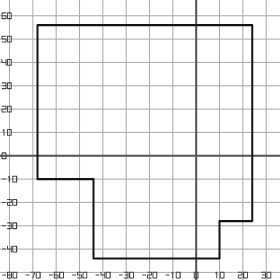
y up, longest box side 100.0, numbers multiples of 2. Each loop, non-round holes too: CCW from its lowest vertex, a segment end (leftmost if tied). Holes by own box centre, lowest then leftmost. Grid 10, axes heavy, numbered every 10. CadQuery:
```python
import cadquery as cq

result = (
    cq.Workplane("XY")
    .moveTo(-44.0, -44.0)
    .lineTo(10.0, -44.0)
    .lineTo(10.0, -28.0)
    .lineTo(24.0, -28.0)
    .lineTo(24.0, 56.0)
    .lineTo(-68.0, 56.0)
    .lineTo(-68.0, -10.0)
    .lineTo(-44.0, -10.0)
    .close()
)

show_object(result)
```